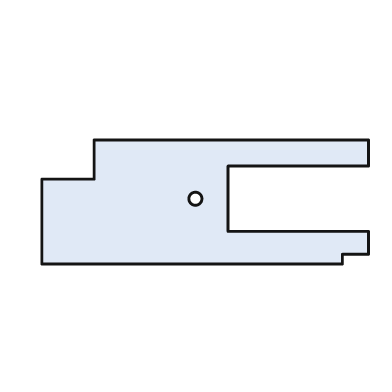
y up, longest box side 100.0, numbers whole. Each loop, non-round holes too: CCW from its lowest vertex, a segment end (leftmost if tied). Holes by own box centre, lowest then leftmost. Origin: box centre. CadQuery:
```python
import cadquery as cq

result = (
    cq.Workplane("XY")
    .moveTo(-50.0, -19.0)
    .lineTo(42.0, -19.0)
    .lineTo(42.0, -16.0)
    .lineTo(50.0, -16.0)
    .lineTo(50.0, -9.0)
    .lineTo(7.0, -9.0)
    .lineTo(7.0, 11.0)
    .lineTo(50.0, 11.0)
    .lineTo(50.0, 19.0)
    .lineTo(-34.0, 19.0)
    .lineTo(-34.0, 7.0)
    .lineTo(-50.0, 7.0)
    .close()
    .moveTo(-3.0, 1.0)
    .circle(2.0)
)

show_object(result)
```